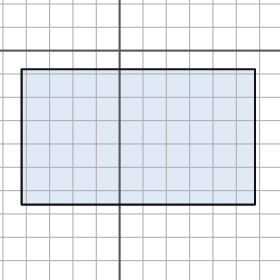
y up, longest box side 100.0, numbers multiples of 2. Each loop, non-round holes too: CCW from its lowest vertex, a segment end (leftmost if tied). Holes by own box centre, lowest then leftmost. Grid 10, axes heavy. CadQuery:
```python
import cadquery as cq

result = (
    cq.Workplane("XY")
    .moveTo(-42.0, -66.0)
    .lineTo(58.0, -66.0)
    .lineTo(58.0, -8.0)
    .lineTo(-42.0, -8.0)
    .close()
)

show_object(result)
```